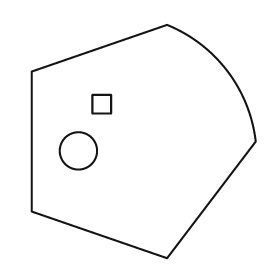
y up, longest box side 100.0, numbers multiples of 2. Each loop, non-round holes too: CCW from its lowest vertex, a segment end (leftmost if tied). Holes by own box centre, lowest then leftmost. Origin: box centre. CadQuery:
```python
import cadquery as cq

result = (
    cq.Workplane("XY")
    .moveTo(10.0, -50.0)
    .lineTo(48.0, 0.0)
    .threePointArc((36.0, 30.0), (10.0, 50.0))
    .lineTo(-48.0, 30.0)
    .lineTo(-48.0, -30.0)
    .close()
    .moveTo(-28.0, -4.0)
    .circle(8.0)
    .moveTo(-22.0, 12.0)
    .lineTo(-14.0, 12.0)
    .lineTo(-14.0, 20.0)
    .lineTo(-22.0, 20.0)
    .close()
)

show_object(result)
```